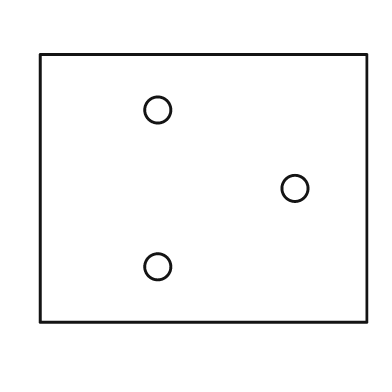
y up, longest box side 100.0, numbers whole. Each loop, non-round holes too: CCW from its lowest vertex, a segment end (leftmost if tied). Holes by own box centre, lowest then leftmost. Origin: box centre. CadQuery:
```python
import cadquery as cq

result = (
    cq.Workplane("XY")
    .moveTo(-50.0, -41.0)
    .lineTo(50.0, -41.0)
    .lineTo(50.0, 41.0)
    .lineTo(-50.0, 41.0)
    .close()
    .moveTo(-14.0, -24.0)
    .circle(4.0)
    .moveTo(28.0, 0.0)
    .circle(4.0)
    .moveTo(-14.0, 24.0)
    .circle(4.0)
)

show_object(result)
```